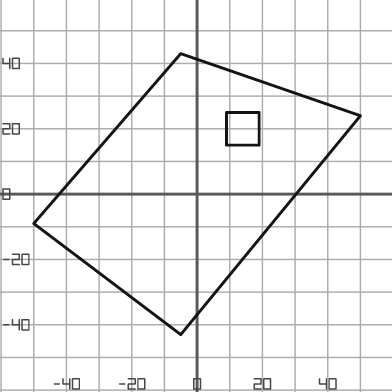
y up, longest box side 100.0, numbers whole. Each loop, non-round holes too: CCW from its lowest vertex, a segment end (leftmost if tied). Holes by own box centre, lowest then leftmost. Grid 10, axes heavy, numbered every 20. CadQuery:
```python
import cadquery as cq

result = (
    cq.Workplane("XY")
    .moveTo(-5.0, -43.0)
    .lineTo(50.0, 24.0)
    .lineTo(-5.0, 43.0)
    .lineTo(-50.0, -9.0)
    .close()
    .moveTo(9.0, 15.0)
    .lineTo(19.0, 15.0)
    .lineTo(19.0, 25.0)
    .lineTo(9.0, 25.0)
    .close()
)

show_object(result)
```